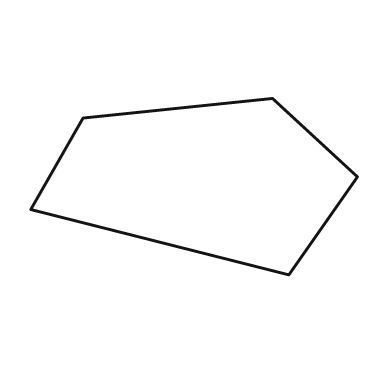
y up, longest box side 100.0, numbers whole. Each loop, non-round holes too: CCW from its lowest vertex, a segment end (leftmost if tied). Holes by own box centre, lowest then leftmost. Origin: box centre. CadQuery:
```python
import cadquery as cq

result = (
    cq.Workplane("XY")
    .moveTo(29.0, -27.0)
    .lineTo(50.0, 3.0)
    .lineTo(24.0, 27.0)
    .lineTo(-34.0, 21.0)
    .lineTo(-50.0, -7.0)
    .close()
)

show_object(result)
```